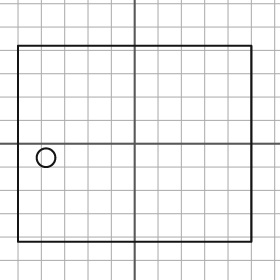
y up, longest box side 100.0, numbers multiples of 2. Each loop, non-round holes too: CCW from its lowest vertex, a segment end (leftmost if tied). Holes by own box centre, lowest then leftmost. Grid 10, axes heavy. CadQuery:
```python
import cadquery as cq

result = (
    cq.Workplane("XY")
    .moveTo(-50.0, -42.0)
    .lineTo(50.0, -42.0)
    .lineTo(50.0, 42.0)
    .lineTo(-50.0, 42.0)
    .close()
    .moveTo(-38.0, -6.0)
    .circle(4.0)
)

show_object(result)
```